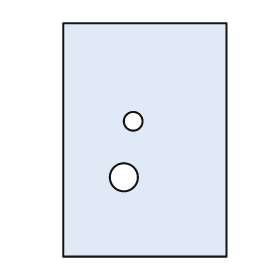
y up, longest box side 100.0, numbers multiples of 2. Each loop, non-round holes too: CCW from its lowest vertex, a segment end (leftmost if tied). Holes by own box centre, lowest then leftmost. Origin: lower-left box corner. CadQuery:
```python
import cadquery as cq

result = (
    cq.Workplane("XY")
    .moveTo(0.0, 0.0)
    .lineTo(70.0, 0.0)
    .lineTo(70.0, 100.0)
    .lineTo(0.0, 100.0)
    .close()
    .moveTo(26.0, 34.0)
    .circle(6.0)
    .moveTo(30.0, 58.0)
    .circle(4.0)
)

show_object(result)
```